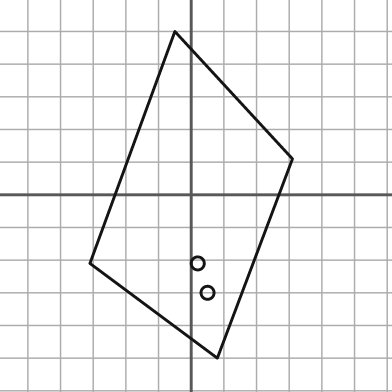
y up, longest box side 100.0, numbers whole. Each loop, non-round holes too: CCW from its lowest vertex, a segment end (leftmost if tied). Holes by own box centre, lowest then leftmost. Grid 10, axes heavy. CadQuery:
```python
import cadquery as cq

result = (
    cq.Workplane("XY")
    .moveTo(8.0, -50.0)
    .lineTo(31.0, 11.0)
    .lineTo(-5.0, 50.0)
    .lineTo(-31.0, -21.0)
    .close()
    .moveTo(5.0, -30.0)
    .circle(2.0)
    .moveTo(2.0, -21.0)
    .circle(2.0)
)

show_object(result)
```